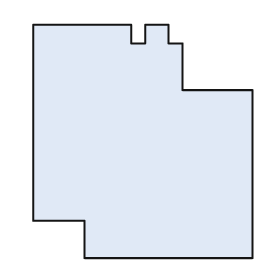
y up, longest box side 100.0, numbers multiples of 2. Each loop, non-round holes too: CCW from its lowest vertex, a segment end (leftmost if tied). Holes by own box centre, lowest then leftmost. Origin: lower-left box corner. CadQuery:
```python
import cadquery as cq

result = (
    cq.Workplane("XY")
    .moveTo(22.0, 0.0)
    .lineTo(94.0, 0.0)
    .lineTo(94.0, 72.0)
    .lineTo(64.0, 72.0)
    .lineTo(64.0, 92.0)
    .lineTo(58.0, 92.0)
    .lineTo(58.0, 100.0)
    .lineTo(48.0, 100.0)
    .lineTo(48.0, 92.0)
    .lineTo(42.0, 92.0)
    .lineTo(42.0, 100.0)
    .lineTo(0.0, 100.0)
    .lineTo(0.0, 16.0)
    .lineTo(22.0, 16.0)
    .close()
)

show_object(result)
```